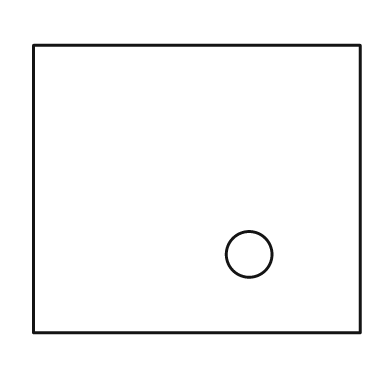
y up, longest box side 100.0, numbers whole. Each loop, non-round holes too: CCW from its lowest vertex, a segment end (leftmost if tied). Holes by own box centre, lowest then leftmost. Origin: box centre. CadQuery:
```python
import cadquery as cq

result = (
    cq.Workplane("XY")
    .moveTo(-50.0, -44.0)
    .lineTo(50.0, -44.0)
    .lineTo(50.0, 44.0)
    .lineTo(-50.0, 44.0)
    .close()
    .moveTo(16.0, -20.0)
    .circle(7.0)
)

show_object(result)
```